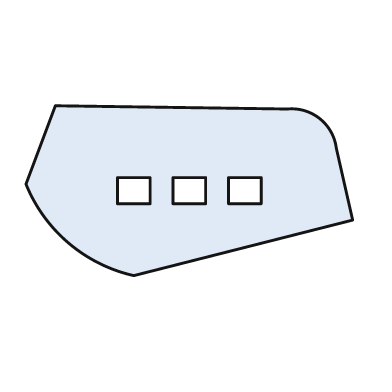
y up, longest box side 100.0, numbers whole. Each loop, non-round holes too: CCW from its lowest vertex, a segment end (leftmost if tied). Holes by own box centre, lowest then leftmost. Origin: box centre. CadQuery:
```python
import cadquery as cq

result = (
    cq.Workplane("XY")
    .moveTo(-17.0, -26.0)
    .lineTo(50.0, -9.0)
    .lineTo(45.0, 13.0)
    .threePointArc((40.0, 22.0), (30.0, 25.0))
    .lineTo(-41.0, 26.0)
    .lineTo(-50.0, 2.0)
    .threePointArc((-37.0, -16.0), (-17.0, -26.0))
    .close()
    .moveTo(-22.0, -4.0)
    .lineTo(-12.0, -4.0)
    .lineTo(-12.0, 4.0)
    .lineTo(-22.0, 4.0)
    .close()
    .moveTo(-5.0, -4.0)
    .lineTo(5.0, -4.0)
    .lineTo(5.0, 4.0)
    .lineTo(-5.0, 4.0)
    .close()
    .moveTo(12.0, -4.0)
    .lineTo(22.0, -4.0)
    .lineTo(22.0, 4.0)
    .lineTo(12.0, 4.0)
    .close()
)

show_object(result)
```